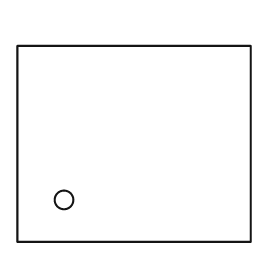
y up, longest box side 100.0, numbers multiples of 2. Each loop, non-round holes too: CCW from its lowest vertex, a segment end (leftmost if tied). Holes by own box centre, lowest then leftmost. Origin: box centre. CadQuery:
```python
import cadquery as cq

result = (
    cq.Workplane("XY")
    .moveTo(-50.0, -42.0)
    .lineTo(50.0, -42.0)
    .lineTo(50.0, 42.0)
    .lineTo(-50.0, 42.0)
    .close()
    .moveTo(-30.0, -24.0)
    .circle(4.0)
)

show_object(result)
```